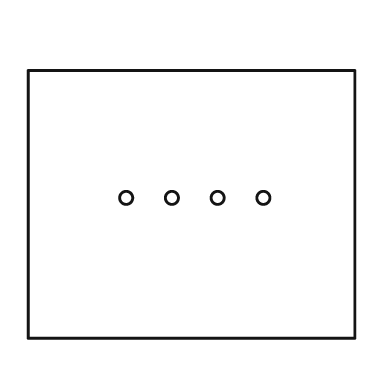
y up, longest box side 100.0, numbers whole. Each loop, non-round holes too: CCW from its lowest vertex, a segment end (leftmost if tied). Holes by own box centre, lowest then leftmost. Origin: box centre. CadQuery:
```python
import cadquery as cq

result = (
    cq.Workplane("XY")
    .moveTo(-50.0, -41.0)
    .lineTo(50.0, -41.0)
    .lineTo(50.0, 41.0)
    .lineTo(-50.0, 41.0)
    .close()
    .moveTo(-20.0, 2.0)
    .circle(2.0)
    .moveTo(-6.0, 2.0)
    .circle(2.0)
    .moveTo(8.0, 2.0)
    .circle(2.0)
    .moveTo(22.0, 2.0)
    .circle(2.0)
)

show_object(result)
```